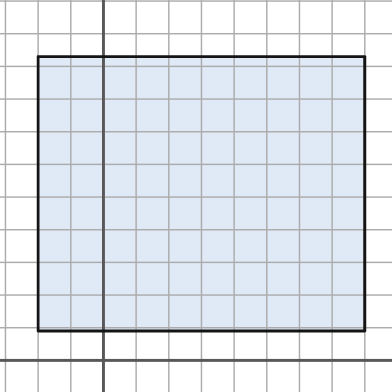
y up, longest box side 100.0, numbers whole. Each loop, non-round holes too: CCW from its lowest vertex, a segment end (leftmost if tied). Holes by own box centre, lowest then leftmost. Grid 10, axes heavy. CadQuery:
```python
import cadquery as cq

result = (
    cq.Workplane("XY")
    .moveTo(-20.0, 9.0)
    .lineTo(80.0, 9.0)
    .lineTo(80.0, 93.0)
    .lineTo(-20.0, 93.0)
    .close()
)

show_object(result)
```